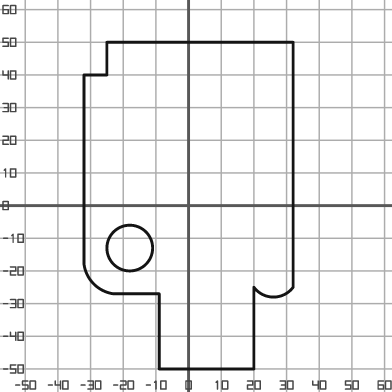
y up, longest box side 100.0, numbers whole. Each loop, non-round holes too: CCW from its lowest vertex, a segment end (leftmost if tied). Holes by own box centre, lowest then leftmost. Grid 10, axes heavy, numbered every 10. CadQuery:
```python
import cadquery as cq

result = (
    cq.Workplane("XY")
    .moveTo(-9.0, -50.0)
    .lineTo(20.0, -50.0)
    .lineTo(20.0, -25.0)
    .threePointArc((26.0, -28.0), (32.0, -25.0))
    .lineTo(32.0, 50.0)
    .lineTo(-25.0, 50.0)
    .lineTo(-25.0, 40.0)
    .lineTo(-32.0, 40.0)
    .lineTo(-32.0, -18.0)
    .threePointArc((-29.0, -24.0), (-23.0, -27.0))
    .lineTo(-9.0, -27.0)
    .close()
    .moveTo(-18.0, -13.0)
    .circle(7.0)
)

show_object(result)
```